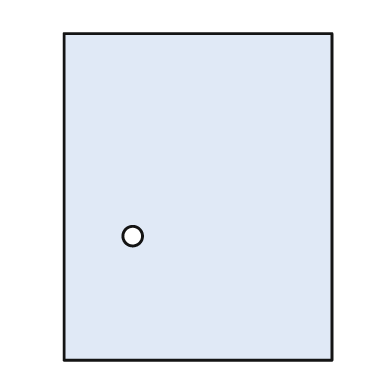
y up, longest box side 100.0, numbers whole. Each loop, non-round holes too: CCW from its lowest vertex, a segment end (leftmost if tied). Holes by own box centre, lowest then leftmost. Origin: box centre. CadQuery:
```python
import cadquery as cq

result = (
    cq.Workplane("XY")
    .moveTo(-41.0, -50.0)
    .lineTo(41.0, -50.0)
    .lineTo(41.0, 50.0)
    .lineTo(-41.0, 50.0)
    .close()
    .moveTo(-20.0, -12.0)
    .circle(3.0)
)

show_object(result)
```